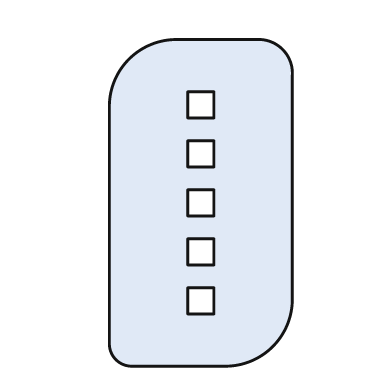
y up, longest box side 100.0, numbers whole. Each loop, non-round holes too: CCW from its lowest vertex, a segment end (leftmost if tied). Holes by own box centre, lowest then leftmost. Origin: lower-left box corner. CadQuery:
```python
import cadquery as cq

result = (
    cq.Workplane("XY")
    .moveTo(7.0, 0.0)
    .lineTo(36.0, 0.0)
    .threePointArc((50.0, 6.0), (56.0, 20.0))
    .lineTo(56.0, 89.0)
    .threePointArc((53.0, 97.0), (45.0, 100.0))
    .lineTo(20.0, 100.0)
    .threePointArc((6.0, 94.0), (0.0, 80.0))
    .lineTo(0.0, 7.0)
    .threePointArc((2.0, 2.0), (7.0, 0.0))
    .close()
    .moveTo(24.0, 16.0)
    .lineTo(32.0, 16.0)
    .lineTo(32.0, 24.0)
    .lineTo(24.0, 24.0)
    .close()
    .moveTo(24.0, 31.0)
    .lineTo(32.0, 31.0)
    .lineTo(32.0, 39.0)
    .lineTo(24.0, 39.0)
    .close()
    .moveTo(24.0, 46.0)
    .lineTo(32.0, 46.0)
    .lineTo(32.0, 54.0)
    .lineTo(24.0, 54.0)
    .close()
    .moveTo(24.0, 61.0)
    .lineTo(32.0, 61.0)
    .lineTo(32.0, 69.0)
    .lineTo(24.0, 69.0)
    .close()
    .moveTo(24.0, 76.0)
    .lineTo(32.0, 76.0)
    .lineTo(32.0, 84.0)
    .lineTo(24.0, 84.0)
    .close()
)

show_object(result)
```